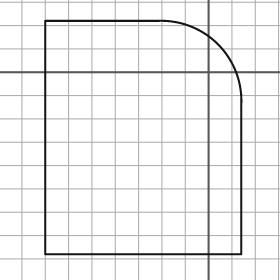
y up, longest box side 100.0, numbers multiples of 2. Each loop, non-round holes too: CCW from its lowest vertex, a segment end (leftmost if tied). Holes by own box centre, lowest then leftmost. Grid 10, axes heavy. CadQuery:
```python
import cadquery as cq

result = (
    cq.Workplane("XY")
    .moveTo(-70.0, -78.0)
    .lineTo(14.0, -78.0)
    .lineTo(14.0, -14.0)
    .threePointArc((4.0, 12.0), (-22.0, 22.0))
    .lineTo(-70.0, 22.0)
    .close()
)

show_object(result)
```